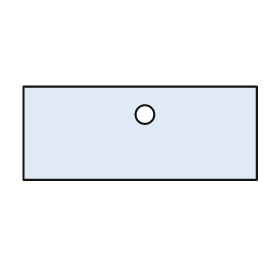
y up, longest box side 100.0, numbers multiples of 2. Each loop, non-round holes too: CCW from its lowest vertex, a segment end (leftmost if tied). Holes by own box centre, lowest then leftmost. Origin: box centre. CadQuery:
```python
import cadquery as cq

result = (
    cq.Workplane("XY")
    .moveTo(-50.0, -20.0)
    .lineTo(50.0, -20.0)
    .lineTo(50.0, 20.0)
    .lineTo(-50.0, 20.0)
    .close()
    .moveTo(2.0, 8.0)
    .circle(4.0)
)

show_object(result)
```